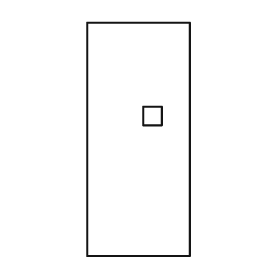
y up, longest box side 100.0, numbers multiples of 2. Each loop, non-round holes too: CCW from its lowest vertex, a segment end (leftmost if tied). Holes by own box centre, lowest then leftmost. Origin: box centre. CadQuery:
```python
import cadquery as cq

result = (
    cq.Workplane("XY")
    .moveTo(-22.0, -50.0)
    .lineTo(22.0, -50.0)
    .lineTo(22.0, 50.0)
    .lineTo(-22.0, 50.0)
    .close()
    .moveTo(2.0, 6.0)
    .lineTo(10.0, 6.0)
    .lineTo(10.0, 14.0)
    .lineTo(2.0, 14.0)
    .close()
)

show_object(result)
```